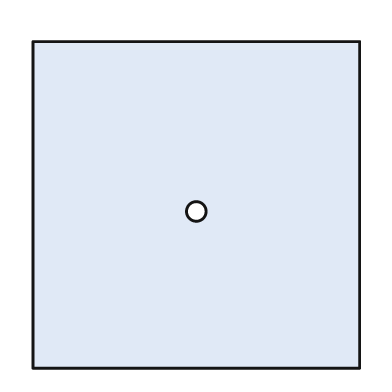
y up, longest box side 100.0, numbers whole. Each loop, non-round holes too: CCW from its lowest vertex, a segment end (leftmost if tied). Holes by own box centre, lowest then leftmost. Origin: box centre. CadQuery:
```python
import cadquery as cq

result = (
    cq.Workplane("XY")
    .moveTo(-50.0, -50.0)
    .lineTo(50.0, -50.0)
    .lineTo(50.0, 50.0)
    .lineTo(-50.0, 50.0)
    .close()
    .moveTo(0.0, -2.0)
    .circle(3.0)
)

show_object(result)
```